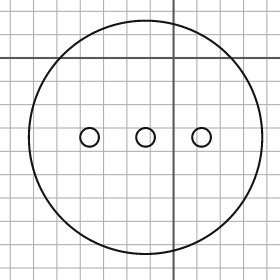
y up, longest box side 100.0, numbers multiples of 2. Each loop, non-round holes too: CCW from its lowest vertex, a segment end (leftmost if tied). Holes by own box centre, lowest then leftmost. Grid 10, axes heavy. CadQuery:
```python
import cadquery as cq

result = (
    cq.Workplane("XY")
    .moveTo(-12.0, -34.0)
    .circle(50.0)
    .moveTo(-36.0, -34.0)
    .circle(4.0)
    .moveTo(-12.0, -34.0)
    .circle(4.0)
    .moveTo(12.0, -34.0)
    .circle(4.0)
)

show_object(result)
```